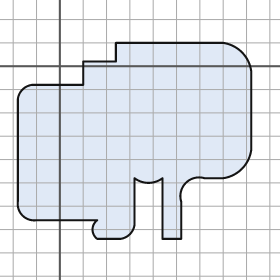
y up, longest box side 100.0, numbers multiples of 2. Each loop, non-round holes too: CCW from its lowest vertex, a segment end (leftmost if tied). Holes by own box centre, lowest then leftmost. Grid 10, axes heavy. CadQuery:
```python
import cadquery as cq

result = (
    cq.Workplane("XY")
    .moveTo(16.0, -74.0)
    .lineTo(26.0, -74.0)
    .threePointArc((30.0, -72.0), (32.0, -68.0))
    .lineTo(32.0, -48.0)
    .threePointArc((38.0, -50.0), (44.0, -48.0))
    .lineTo(44.0, -74.0)
    .lineTo(52.0, -74.0)
    .lineTo(52.0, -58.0)
    .threePointArc((54.0, -50.0), (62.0, -48.0))
    .lineTo(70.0, -48.0)
    .threePointArc((78.0, -44.0), (82.0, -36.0))
    .lineTo(82.0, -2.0)
    .threePointArc((78.0, 6.0), (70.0, 10.0))
    .lineTo(24.0, 10.0)
    .lineTo(24.0, 2.0)
    .lineTo(10.0, 2.0)
    .lineTo(10.0, -8.0)
    .lineTo(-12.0, -8.0)
    .threePointArc((-16.0, -10.0), (-18.0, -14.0))
    .lineTo(-18.0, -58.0)
    .threePointArc((-16.0, -64.0), (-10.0, -66.0))
    .lineTo(16.0, -66.0)
    .threePointArc((14.0, -70.0), (16.0, -74.0))
    .close()
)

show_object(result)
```